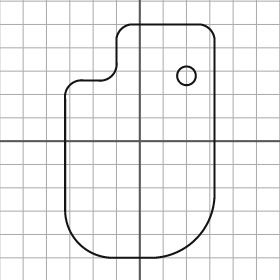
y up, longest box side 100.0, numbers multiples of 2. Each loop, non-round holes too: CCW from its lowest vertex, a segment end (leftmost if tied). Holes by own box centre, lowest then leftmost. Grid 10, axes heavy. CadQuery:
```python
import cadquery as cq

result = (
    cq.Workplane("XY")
    .moveTo(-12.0, -50.0)
    .lineTo(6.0, -50.0)
    .threePointArc((24.0, -42.0), (32.0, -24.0))
    .lineTo(32.0, 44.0)
    .threePointArc((30.0, 48.0), (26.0, 50.0))
    .lineTo(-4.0, 50.0)
    .threePointArc((-8.0, 48.0), (-10.0, 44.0))
    .lineTo(-10.0, 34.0)
    .threePointArc((-12.0, 28.0), (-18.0, 26.0))
    .lineTo(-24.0, 26.0)
    .threePointArc((-30.0, 24.0), (-32.0, 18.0))
    .lineTo(-32.0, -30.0)
    .threePointArc((-26.0, -44.0), (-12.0, -50.0))
    .close()
    .moveTo(20.0, 28.0)
    .circle(4.0)
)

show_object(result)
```